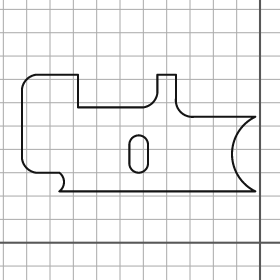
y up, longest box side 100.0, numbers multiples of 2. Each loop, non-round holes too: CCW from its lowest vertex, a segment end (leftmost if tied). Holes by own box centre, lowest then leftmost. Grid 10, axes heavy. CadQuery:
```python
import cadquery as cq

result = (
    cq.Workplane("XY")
    .moveTo(-86.0, 22.0)
    .lineTo(-2.0, 22.0)
    .threePointArc((-12.0, 38.0), (-2.0, 54.0))
    .lineTo(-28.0, 54.0)
    .threePointArc((-34.0, 56.0), (-36.0, 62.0))
    .lineTo(-36.0, 72.0)
    .lineTo(-44.0, 72.0)
    .lineTo(-44.0, 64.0)
    .threePointArc((-46.0, 60.0), (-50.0, 58.0))
    .lineTo(-78.0, 58.0)
    .lineTo(-78.0, 72.0)
    .lineTo(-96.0, 72.0)
    .threePointArc((-100.0, 70.0), (-102.0, 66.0))
    .lineTo(-102.0, 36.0)
    .threePointArc((-100.0, 32.0), (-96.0, 30.0))
    .lineTo(-86.0, 30.0)
    .threePointArc((-84.0, 26.0), (-86.0, 22.0))
    .close()
    .moveTo(-56.0, 34.0)
    .threePointArc((-52.0, 30.0), (-48.0, 34.0))
    .lineTo(-48.0, 42.0)
    .threePointArc((-52.0, 46.0), (-56.0, 42.0))
    .close()
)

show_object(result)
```